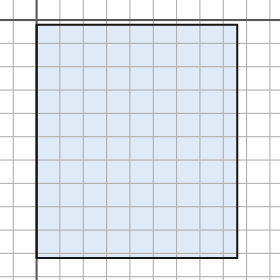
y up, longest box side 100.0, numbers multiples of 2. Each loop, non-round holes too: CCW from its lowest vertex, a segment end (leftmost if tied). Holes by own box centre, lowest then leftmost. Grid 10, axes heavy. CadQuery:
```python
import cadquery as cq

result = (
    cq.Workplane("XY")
    .moveTo(0.0, -102.0)
    .lineTo(86.0, -102.0)
    .lineTo(86.0, -2.0)
    .lineTo(0.0, -2.0)
    .close()
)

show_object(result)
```